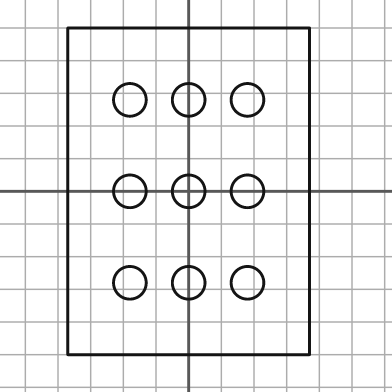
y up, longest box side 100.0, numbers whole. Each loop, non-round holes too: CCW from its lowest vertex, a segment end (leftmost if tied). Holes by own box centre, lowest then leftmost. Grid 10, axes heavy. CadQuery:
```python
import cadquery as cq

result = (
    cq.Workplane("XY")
    .moveTo(-37.0, -50.0)
    .lineTo(37.0, -50.0)
    .lineTo(37.0, 50.0)
    .lineTo(-37.0, 50.0)
    .close()
    .moveTo(-18.0, -28.0)
    .circle(5.0)
    .moveTo(0.0, -28.0)
    .circle(5.0)
    .moveTo(18.0, -28.0)
    .circle(5.0)
    .moveTo(-18.0, 0.0)
    .circle(5.0)
    .moveTo(0.0, 0.0)
    .circle(5.0)
    .moveTo(18.0, 0.0)
    .circle(5.0)
    .moveTo(-18.0, 28.0)
    .circle(5.0)
    .moveTo(0.0, 28.0)
    .circle(5.0)
    .moveTo(18.0, 28.0)
    .circle(5.0)
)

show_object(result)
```